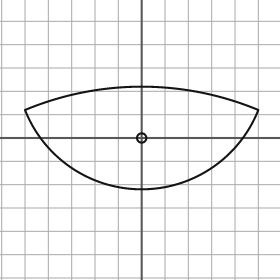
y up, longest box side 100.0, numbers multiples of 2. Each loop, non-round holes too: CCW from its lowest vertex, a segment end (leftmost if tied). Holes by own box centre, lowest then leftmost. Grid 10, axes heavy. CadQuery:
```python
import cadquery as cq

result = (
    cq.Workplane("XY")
    .moveTo(-50.0, 12.0)
    .threePointArc((0.0, -22.0), (50.0, 12.0))
    .threePointArc((0.0, 22.0), (-50.0, 12.0))
    .close()
    .moveTo(0.0, 0.0)
    .circle(2.0)
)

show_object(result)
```